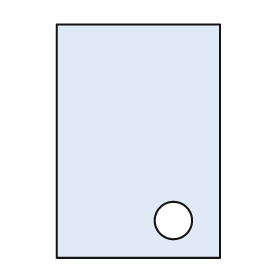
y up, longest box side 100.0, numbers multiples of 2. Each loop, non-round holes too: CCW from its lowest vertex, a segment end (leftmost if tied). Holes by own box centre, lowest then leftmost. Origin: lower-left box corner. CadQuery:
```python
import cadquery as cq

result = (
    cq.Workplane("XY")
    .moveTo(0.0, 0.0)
    .lineTo(70.0, 0.0)
    .lineTo(70.0, 100.0)
    .lineTo(0.0, 100.0)
    .close()
    .moveTo(50.0, 16.0)
    .circle(8.0)
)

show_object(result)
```